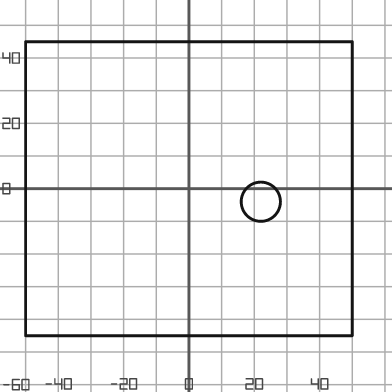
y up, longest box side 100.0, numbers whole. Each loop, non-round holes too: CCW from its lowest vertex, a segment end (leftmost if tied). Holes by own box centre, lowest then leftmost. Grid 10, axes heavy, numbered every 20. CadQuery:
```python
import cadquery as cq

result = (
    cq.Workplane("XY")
    .moveTo(-50.0, -45.0)
    .lineTo(50.0, -45.0)
    .lineTo(50.0, 45.0)
    .lineTo(-50.0, 45.0)
    .close()
    .moveTo(22.0, -4.0)
    .circle(6.0)
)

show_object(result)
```